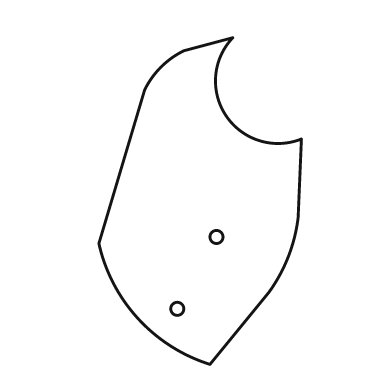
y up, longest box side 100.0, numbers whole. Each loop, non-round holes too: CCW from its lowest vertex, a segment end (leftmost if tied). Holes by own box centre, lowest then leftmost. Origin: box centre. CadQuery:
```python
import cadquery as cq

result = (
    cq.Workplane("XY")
    .moveTo(3.0, -50.0)
    .lineTo(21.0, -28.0)
    .threePointArc((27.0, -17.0), (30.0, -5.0))
    .lineTo(31.0, 19.0)
    .threePointArc((8.0, 26.0), (10.0, 50.0))
    .lineTo(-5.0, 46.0)
    .threePointArc((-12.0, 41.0), (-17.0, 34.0))
    .lineTo(-31.0, -13.0)
    .threePointArc((-19.0, -36.0), (3.0, -50.0))
    .close()
    .moveTo(-7.0, -33.0)
    .circle(2.0)
    .moveTo(5.0, -11.0)
    .circle(2.0)
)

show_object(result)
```